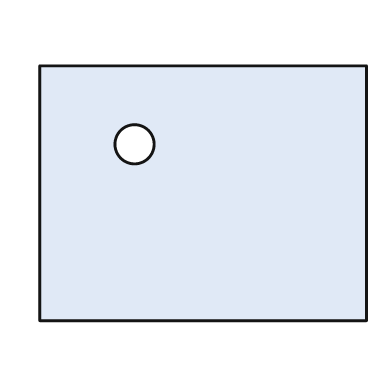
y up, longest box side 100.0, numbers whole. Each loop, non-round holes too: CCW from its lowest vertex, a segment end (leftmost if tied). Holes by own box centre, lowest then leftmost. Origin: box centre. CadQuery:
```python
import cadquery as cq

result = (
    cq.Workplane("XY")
    .moveTo(-50.0, -39.0)
    .lineTo(50.0, -39.0)
    .lineTo(50.0, 39.0)
    .lineTo(-50.0, 39.0)
    .close()
    .moveTo(-21.0, 15.0)
    .circle(6.0)
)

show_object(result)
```